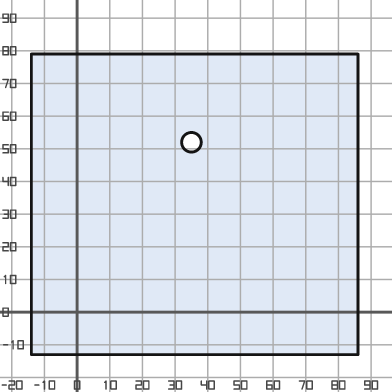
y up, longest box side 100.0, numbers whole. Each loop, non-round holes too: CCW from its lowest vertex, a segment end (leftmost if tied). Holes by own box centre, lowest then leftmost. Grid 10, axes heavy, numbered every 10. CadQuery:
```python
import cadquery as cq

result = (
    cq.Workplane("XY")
    .moveTo(-14.0, -13.0)
    .lineTo(86.0, -13.0)
    .lineTo(86.0, 79.0)
    .lineTo(-14.0, 79.0)
    .close()
    .moveTo(35.0, 52.0)
    .circle(3.0)
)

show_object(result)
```